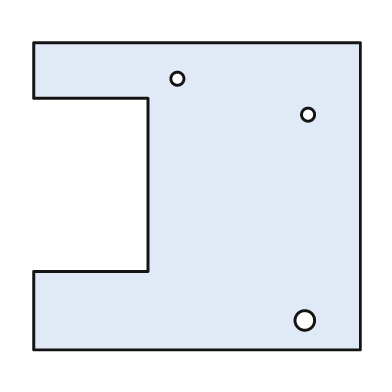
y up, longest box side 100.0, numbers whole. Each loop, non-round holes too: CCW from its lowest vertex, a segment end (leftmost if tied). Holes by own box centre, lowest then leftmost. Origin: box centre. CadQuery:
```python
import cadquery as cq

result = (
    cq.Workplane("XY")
    .moveTo(-50.0, -47.0)
    .lineTo(50.0, -47.0)
    .lineTo(50.0, 47.0)
    .lineTo(-50.0, 47.0)
    .lineTo(-50.0, 30.0)
    .lineTo(-15.0, 30.0)
    .lineTo(-15.0, -23.0)
    .lineTo(-50.0, -23.0)
    .close()
    .moveTo(33.0, -38.0)
    .circle(3.0)
    .moveTo(34.0, 25.0)
    .circle(2.0)
    .moveTo(-6.0, 36.0)
    .circle(2.0)
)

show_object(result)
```